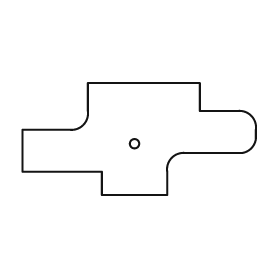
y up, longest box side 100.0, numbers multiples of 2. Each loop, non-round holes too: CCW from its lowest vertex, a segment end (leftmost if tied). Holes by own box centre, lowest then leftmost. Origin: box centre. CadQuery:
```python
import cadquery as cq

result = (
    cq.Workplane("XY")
    .moveTo(-16.0, -24.0)
    .lineTo(12.0, -24.0)
    .lineTo(12.0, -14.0)
    .threePointArc((14.0, -8.0), (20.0, -6.0))
    .lineTo(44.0, -6.0)
    .threePointArc((48.0, -4.0), (50.0, 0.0))
    .lineTo(50.0, 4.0)
    .threePointArc((48.0, 10.0), (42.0, 12.0))
    .lineTo(26.0, 12.0)
    .lineTo(26.0, 24.0)
    .lineTo(-22.0, 24.0)
    .lineTo(-22.0, 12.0)
    .threePointArc((-24.0, 6.0), (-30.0, 4.0))
    .lineTo(-50.0, 4.0)
    .lineTo(-50.0, -14.0)
    .lineTo(-16.0, -14.0)
    .close()
    .moveTo(-2.0, -2.0)
    .circle(2.0)
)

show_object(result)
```